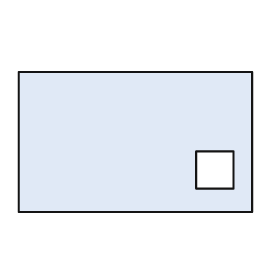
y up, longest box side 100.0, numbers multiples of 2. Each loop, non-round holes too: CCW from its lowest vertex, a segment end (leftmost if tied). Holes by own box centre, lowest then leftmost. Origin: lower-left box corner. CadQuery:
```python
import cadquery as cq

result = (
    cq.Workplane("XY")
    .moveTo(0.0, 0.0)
    .lineTo(100.0, 0.0)
    .lineTo(100.0, 60.0)
    .lineTo(0.0, 60.0)
    .close()
    .moveTo(76.0, 10.0)
    .lineTo(92.0, 10.0)
    .lineTo(92.0, 26.0)
    .lineTo(76.0, 26.0)
    .close()
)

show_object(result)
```